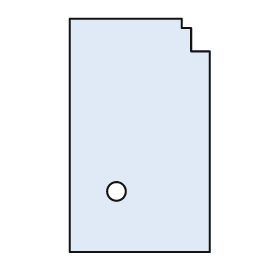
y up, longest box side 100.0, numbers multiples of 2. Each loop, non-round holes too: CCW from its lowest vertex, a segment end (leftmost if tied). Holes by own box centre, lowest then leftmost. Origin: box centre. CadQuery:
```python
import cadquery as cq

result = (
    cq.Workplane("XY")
    .moveTo(-30.0, -50.0)
    .lineTo(30.0, -50.0)
    .lineTo(30.0, 36.0)
    .lineTo(22.0, 36.0)
    .lineTo(22.0, 46.0)
    .lineTo(18.0, 46.0)
    .lineTo(18.0, 50.0)
    .lineTo(-30.0, 50.0)
    .close()
    .moveTo(-10.0, -24.0)
    .circle(4.0)
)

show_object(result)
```